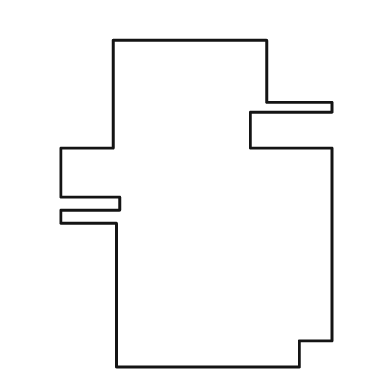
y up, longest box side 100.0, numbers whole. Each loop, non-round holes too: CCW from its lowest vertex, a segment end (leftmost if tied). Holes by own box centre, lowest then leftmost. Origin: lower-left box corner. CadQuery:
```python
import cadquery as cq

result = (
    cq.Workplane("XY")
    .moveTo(17.0, 0.0)
    .lineTo(73.0, 0.0)
    .lineTo(73.0, 8.0)
    .lineTo(83.0, 8.0)
    .lineTo(83.0, 67.0)
    .lineTo(58.0, 67.0)
    .lineTo(58.0, 78.0)
    .lineTo(83.0, 78.0)
    .lineTo(83.0, 81.0)
    .lineTo(63.0, 81.0)
    .lineTo(63.0, 100.0)
    .lineTo(16.0, 100.0)
    .lineTo(16.0, 67.0)
    .lineTo(0.0, 67.0)
    .lineTo(0.0, 52.0)
    .lineTo(18.0, 52.0)
    .lineTo(18.0, 48.0)
    .lineTo(0.0, 48.0)
    .lineTo(0.0, 44.0)
    .lineTo(17.0, 44.0)
    .close()
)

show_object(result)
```